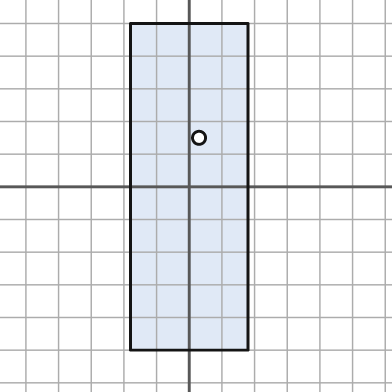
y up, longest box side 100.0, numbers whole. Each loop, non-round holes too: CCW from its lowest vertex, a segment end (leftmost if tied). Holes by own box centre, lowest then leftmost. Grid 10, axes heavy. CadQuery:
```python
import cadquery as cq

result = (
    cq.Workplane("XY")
    .moveTo(-18.0, -50.0)
    .lineTo(18.0, -50.0)
    .lineTo(18.0, 50.0)
    .lineTo(-18.0, 50.0)
    .close()
    .moveTo(3.0, 15.0)
    .circle(2.0)
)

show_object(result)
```